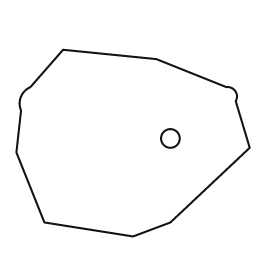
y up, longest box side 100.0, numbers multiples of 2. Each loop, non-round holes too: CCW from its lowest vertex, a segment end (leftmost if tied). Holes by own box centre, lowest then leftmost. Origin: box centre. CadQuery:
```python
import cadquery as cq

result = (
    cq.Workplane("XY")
    .moveTo(0.0, -40.0)
    .lineTo(16.0, -34.0)
    .lineTo(50.0, -2.0)
    .lineTo(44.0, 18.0)
    .threePointArc((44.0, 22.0), (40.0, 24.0))
    .lineTo(10.0, 36.0)
    .lineTo(-30.0, 40.0)
    .lineTo(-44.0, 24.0)
    .threePointArc((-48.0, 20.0), (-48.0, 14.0))
    .lineTo(-50.0, -4.0)
    .lineTo(-38.0, -34.0)
    .close()
    .moveTo(16.0, 2.0)
    .circle(4.0)
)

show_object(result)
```